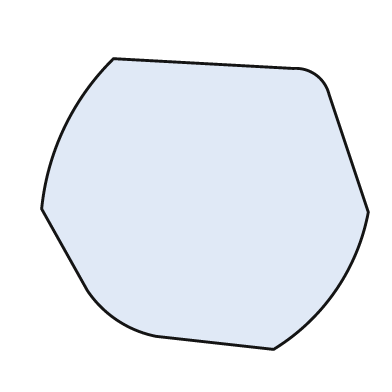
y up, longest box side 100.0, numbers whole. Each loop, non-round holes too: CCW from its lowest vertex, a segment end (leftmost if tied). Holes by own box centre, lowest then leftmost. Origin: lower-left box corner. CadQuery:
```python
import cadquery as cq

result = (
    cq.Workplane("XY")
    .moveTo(71.0, 0.0)
    .threePointArc((90.0, 18.0), (100.0, 42.0))
    .lineTo(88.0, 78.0)
    .threePointArc((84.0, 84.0), (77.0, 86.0))
    .lineTo(22.0, 89.0)
    .threePointArc((7.0, 68.0), (0.0, 43.0))
    .lineTo(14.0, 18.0)
    .threePointArc((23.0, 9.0), (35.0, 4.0))
    .close()
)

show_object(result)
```